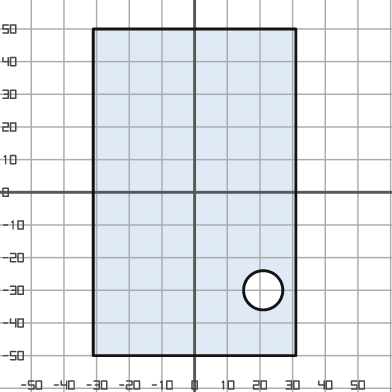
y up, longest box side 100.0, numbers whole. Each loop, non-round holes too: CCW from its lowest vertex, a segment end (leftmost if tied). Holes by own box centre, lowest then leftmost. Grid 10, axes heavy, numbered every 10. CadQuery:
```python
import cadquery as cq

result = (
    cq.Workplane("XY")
    .moveTo(-31.0, -50.0)
    .lineTo(31.0, -50.0)
    .lineTo(31.0, 50.0)
    .lineTo(-31.0, 50.0)
    .close()
    .moveTo(21.0, -30.0)
    .circle(6.0)
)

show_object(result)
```